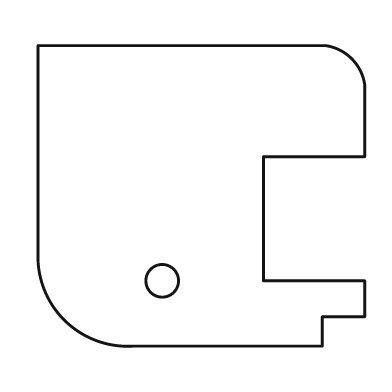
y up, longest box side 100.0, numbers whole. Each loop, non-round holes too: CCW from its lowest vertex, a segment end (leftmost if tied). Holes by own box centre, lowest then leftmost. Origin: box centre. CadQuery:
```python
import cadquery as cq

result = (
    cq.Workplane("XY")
    .moveTo(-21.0, -46.0)
    .lineTo(37.0, -46.0)
    .lineTo(37.0, -37.0)
    .lineTo(50.0, -37.0)
    .lineTo(50.0, -26.0)
    .lineTo(19.0, -26.0)
    .lineTo(19.0, 12.0)
    .lineTo(50.0, 12.0)
    .lineTo(50.0, 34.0)
    .threePointArc((46.0, 42.0), (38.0, 46.0))
    .lineTo(-50.0, 46.0)
    .lineTo(-50.0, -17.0)
    .threePointArc((-42.0, -38.0), (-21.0, -46.0))
    .close()
    .moveTo(-12.0, -26.0)
    .circle(5.0)
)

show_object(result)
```